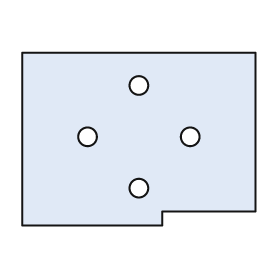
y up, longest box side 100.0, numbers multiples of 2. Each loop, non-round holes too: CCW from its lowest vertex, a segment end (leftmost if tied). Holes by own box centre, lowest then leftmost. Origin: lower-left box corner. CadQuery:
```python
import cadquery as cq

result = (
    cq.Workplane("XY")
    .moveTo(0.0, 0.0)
    .lineTo(60.0, 0.0)
    .lineTo(60.0, 6.0)
    .lineTo(100.0, 6.0)
    .lineTo(100.0, 74.0)
    .lineTo(0.0, 74.0)
    .close()
    .moveTo(50.0, 16.0)
    .circle(4.0)
    .moveTo(28.0, 38.0)
    .circle(4.0)
    .moveTo(72.0, 38.0)
    .circle(4.0)
    .moveTo(50.0, 60.0)
    .circle(4.0)
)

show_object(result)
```